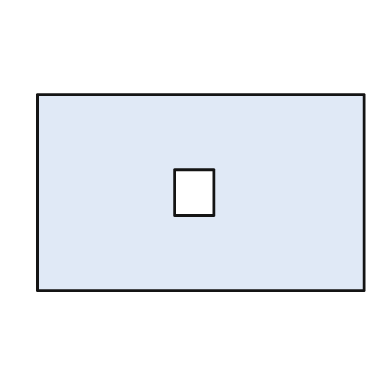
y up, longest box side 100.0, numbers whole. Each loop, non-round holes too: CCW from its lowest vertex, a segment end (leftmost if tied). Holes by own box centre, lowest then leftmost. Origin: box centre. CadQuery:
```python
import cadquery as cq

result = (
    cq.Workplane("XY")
    .moveTo(-50.0, -30.0)
    .lineTo(50.0, -30.0)
    .lineTo(50.0, 30.0)
    .lineTo(-50.0, 30.0)
    .close()
    .moveTo(-8.0, -7.0)
    .lineTo(4.0, -7.0)
    .lineTo(4.0, 7.0)
    .lineTo(-8.0, 7.0)
    .close()
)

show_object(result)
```